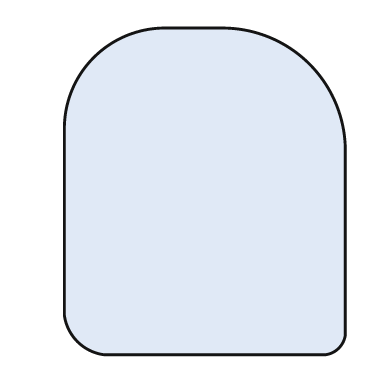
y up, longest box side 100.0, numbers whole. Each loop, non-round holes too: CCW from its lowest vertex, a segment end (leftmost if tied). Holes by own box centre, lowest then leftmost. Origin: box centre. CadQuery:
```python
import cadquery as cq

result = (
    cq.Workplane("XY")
    .moveTo(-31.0, -50.0)
    .lineTo(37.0, -50.0)
    .threePointArc((41.0, -48.0), (43.0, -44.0))
    .lineTo(43.0, 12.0)
    .threePointArc((32.0, 39.0), (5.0, 50.0))
    .lineTo(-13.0, 50.0)
    .threePointArc((-34.0, 41.0), (-43.0, 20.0))
    .lineTo(-43.0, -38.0)
    .threePointArc((-39.0, -46.0), (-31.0, -50.0))
    .close()
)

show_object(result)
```